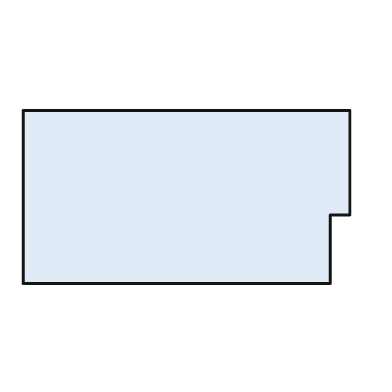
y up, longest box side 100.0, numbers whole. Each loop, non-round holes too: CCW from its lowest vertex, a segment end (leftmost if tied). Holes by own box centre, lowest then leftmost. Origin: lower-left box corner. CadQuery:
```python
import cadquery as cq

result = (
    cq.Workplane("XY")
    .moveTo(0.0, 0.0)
    .lineTo(94.0, 0.0)
    .lineTo(94.0, 21.0)
    .lineTo(100.0, 21.0)
    .lineTo(100.0, 53.0)
    .lineTo(0.0, 53.0)
    .close()
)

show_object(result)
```